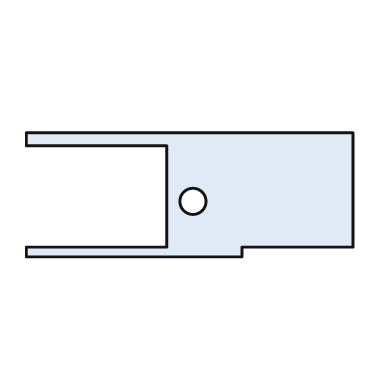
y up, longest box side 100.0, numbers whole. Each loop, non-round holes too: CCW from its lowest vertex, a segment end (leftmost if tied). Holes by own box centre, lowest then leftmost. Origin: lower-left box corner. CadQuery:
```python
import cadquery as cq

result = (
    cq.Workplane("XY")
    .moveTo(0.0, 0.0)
    .lineTo(66.0, 0.0)
    .lineTo(66.0, 3.0)
    .lineTo(100.0, 3.0)
    .lineTo(100.0, 38.0)
    .lineTo(0.0, 38.0)
    .lineTo(0.0, 34.0)
    .lineTo(43.0, 34.0)
    .lineTo(43.0, 3.0)
    .lineTo(0.0, 3.0)
    .close()
    .moveTo(51.0, 17.0)
    .circle(4.0)
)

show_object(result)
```